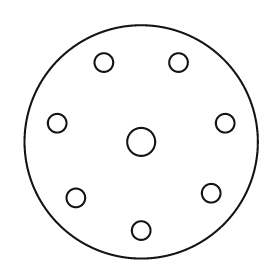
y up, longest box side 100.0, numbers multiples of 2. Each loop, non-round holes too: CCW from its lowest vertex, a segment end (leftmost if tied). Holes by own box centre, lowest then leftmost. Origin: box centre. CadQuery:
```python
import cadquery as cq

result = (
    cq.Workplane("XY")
    .moveTo(0.0, 0.0)
    .circle(50.0)
    .moveTo(0.0, -38.0)
    .circle(4.0)
    .moveTo(-28.0, -24.0)
    .circle(4.0)
    .moveTo(30.0, -22.0)
    .circle(4.0)
    .moveTo(0.0, 0.0)
    .circle(6.0)
    .moveTo(-36.0, 8.0)
    .circle(4.0)
    .moveTo(36.0, 8.0)
    .circle(4.0)
    .moveTo(-16.0, 34.0)
    .circle(4.0)
    .moveTo(16.0, 34.0)
    .circle(4.0)
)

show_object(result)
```